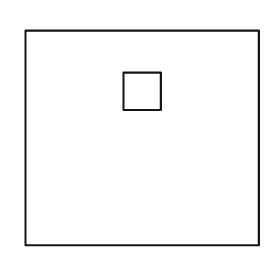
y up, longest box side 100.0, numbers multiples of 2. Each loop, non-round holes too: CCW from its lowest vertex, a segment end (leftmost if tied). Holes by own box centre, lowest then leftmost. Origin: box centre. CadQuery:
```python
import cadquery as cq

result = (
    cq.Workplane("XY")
    .moveTo(-50.0, -46.0)
    .lineTo(50.0, -46.0)
    .lineTo(50.0, 46.0)
    .lineTo(-50.0, 46.0)
    .close()
    .moveTo(-8.0, 12.0)
    .lineTo(8.0, 12.0)
    .lineTo(8.0, 28.0)
    .lineTo(-8.0, 28.0)
    .close()
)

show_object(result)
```